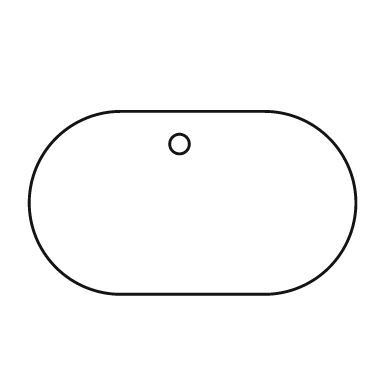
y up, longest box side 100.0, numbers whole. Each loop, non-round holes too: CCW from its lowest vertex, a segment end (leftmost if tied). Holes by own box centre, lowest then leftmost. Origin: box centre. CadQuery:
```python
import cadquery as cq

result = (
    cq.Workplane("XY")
    .moveTo(-22.0, -28.0)
    .lineTo(22.0, -28.0)
    .threePointArc((50.0, 0.0), (22.0, 28.0))
    .lineTo(-22.0, 28.0)
    .threePointArc((-50.0, 0.0), (-22.0, -28.0))
    .close()
    .moveTo(-4.0, 18.0)
    .circle(3.0)
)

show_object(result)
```